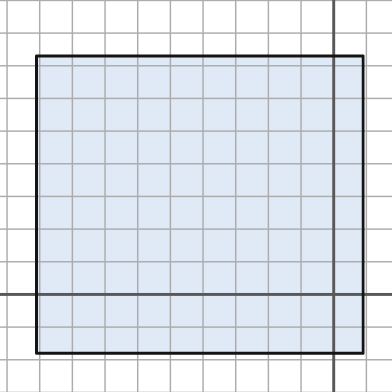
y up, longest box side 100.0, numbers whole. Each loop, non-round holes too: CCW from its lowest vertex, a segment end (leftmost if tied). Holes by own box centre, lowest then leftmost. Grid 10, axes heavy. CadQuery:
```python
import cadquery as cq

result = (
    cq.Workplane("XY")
    .moveTo(-91.0, -18.0)
    .lineTo(9.0, -18.0)
    .lineTo(9.0, 73.0)
    .lineTo(-91.0, 73.0)
    .close()
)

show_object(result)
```